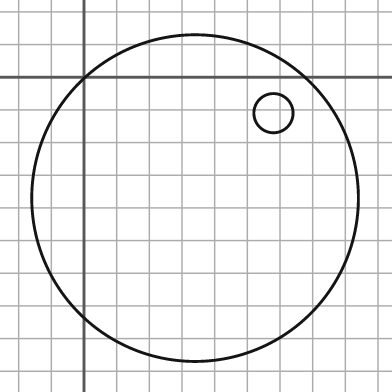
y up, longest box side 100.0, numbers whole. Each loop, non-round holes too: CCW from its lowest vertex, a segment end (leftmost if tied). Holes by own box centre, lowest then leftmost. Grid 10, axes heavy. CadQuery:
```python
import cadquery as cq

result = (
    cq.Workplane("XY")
    .moveTo(34.0, -37.0)
    .circle(50.0)
    .moveTo(58.0, -11.0)
    .circle(6.0)
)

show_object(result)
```